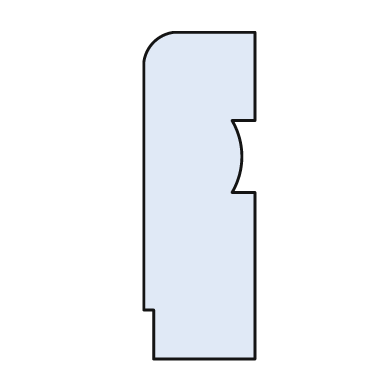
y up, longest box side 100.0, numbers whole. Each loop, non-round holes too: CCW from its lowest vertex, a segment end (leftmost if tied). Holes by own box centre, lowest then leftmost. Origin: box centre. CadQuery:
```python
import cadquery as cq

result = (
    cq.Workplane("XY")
    .moveTo(-14.0, -50.0)
    .lineTo(17.0, -50.0)
    .lineTo(17.0, 1.0)
    .lineTo(10.0, 1.0)
    .threePointArc((13.0, 12.0), (10.0, 23.0))
    .lineTo(17.0, 23.0)
    .lineTo(17.0, 50.0)
    .lineTo(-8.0, 50.0)
    .threePointArc((-14.0, 47.0), (-17.0, 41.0))
    .lineTo(-17.0, -35.0)
    .lineTo(-14.0, -35.0)
    .close()
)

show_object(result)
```